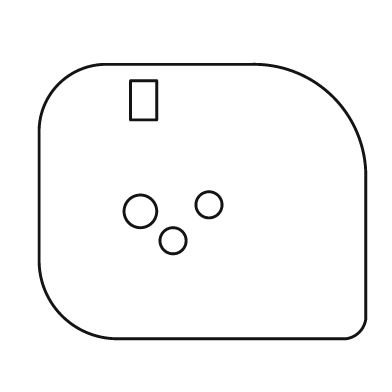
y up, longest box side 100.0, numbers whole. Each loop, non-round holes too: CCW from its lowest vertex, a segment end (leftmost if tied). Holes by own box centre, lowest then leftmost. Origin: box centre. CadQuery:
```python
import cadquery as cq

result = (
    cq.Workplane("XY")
    .moveTo(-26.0, -42.0)
    .lineTo(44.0, -42.0)
    .threePointArc((48.0, -40.0), (50.0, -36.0))
    .lineTo(50.0, 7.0)
    .threePointArc((40.0, 32.0), (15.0, 42.0))
    .lineTo(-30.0, 42.0)
    .threePointArc((-44.0, 36.0), (-50.0, 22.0))
    .lineTo(-50.0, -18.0)
    .threePointArc((-43.0, -35.0), (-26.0, -42.0))
    .close()
    .moveTo(-9.0, -12.0)
    .circle(4.0)
    .moveTo(-19.0, -3.0)
    .circle(5.0)
    .moveTo(2.0, -1.0)
    .circle(4.0)
    .moveTo(-22.0, 25.0)
    .lineTo(-14.0, 25.0)
    .lineTo(-14.0, 37.0)
    .lineTo(-22.0, 37.0)
    .close()
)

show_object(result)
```